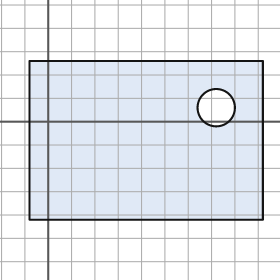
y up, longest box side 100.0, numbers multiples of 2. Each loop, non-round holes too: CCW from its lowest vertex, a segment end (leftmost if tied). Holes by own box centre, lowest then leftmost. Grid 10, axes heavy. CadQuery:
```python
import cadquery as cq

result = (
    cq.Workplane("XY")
    .moveTo(-8.0, -42.0)
    .lineTo(92.0, -42.0)
    .lineTo(92.0, 26.0)
    .lineTo(-8.0, 26.0)
    .close()
    .moveTo(72.0, 6.0)
    .circle(8.0)
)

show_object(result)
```